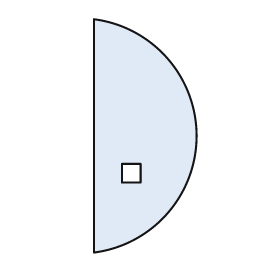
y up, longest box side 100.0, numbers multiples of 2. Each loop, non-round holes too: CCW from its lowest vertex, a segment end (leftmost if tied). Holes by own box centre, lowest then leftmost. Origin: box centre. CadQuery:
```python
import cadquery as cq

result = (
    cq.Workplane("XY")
    .moveTo(-22.0, -50.0)
    .threePointArc((22.0, 0.0), (-22.0, 50.0))
    .close()
    .moveTo(-10.0, -20.0)
    .lineTo(-2.0, -20.0)
    .lineTo(-2.0, -12.0)
    .lineTo(-10.0, -12.0)
    .close()
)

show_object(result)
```